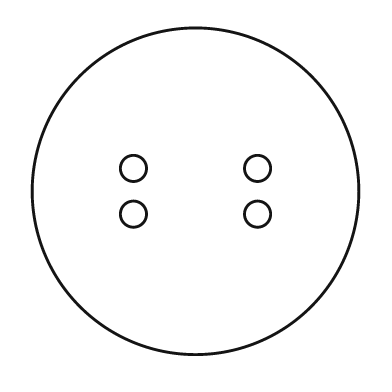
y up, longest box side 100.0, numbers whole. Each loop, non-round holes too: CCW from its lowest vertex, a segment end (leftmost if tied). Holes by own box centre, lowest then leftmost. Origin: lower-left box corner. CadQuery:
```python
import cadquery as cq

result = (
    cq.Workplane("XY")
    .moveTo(50.0, 50.0)
    .circle(50.0)
    .moveTo(31.0, 43.0)
    .circle(4.0)
    .moveTo(69.0, 43.0)
    .circle(4.0)
    .moveTo(31.0, 57.0)
    .circle(4.0)
    .moveTo(69.0, 57.0)
    .circle(4.0)
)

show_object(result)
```